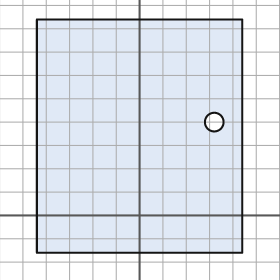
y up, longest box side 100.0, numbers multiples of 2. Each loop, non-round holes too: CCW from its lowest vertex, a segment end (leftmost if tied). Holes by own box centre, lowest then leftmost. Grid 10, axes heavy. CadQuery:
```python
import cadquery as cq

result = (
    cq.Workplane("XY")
    .moveTo(-44.0, -16.0)
    .lineTo(44.0, -16.0)
    .lineTo(44.0, 84.0)
    .lineTo(-44.0, 84.0)
    .close()
    .moveTo(32.0, 40.0)
    .circle(4.0)
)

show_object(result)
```